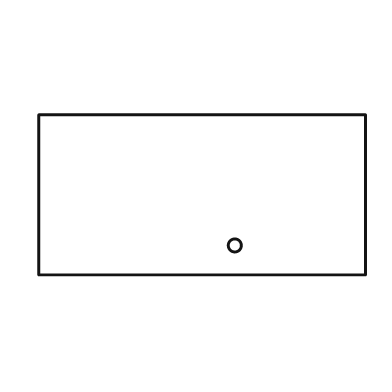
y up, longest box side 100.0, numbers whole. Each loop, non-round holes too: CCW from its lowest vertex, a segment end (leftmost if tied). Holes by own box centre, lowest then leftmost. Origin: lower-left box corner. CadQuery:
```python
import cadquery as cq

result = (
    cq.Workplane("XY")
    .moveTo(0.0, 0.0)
    .lineTo(100.0, 0.0)
    .lineTo(100.0, 49.0)
    .lineTo(0.0, 49.0)
    .close()
    .moveTo(60.0, 9.0)
    .circle(2.0)
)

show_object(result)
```